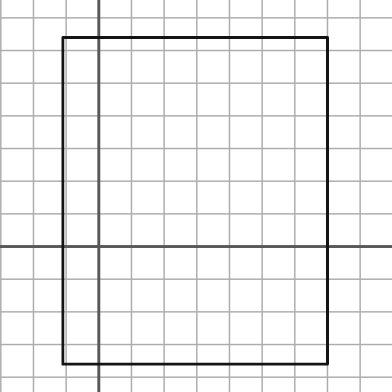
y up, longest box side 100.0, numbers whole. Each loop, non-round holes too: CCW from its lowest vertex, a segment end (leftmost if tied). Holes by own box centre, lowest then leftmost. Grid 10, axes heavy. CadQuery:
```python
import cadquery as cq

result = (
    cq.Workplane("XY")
    .moveTo(-11.0, -36.0)
    .lineTo(70.0, -36.0)
    .lineTo(70.0, 64.0)
    .lineTo(-11.0, 64.0)
    .close()
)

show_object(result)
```